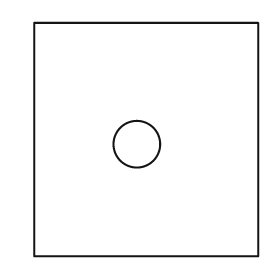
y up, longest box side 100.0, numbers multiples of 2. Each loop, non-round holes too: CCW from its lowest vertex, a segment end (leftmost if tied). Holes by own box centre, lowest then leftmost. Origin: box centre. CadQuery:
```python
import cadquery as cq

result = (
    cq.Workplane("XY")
    .moveTo(-48.0, -50.0)
    .lineTo(48.0, -50.0)
    .lineTo(48.0, 50.0)
    .lineTo(-48.0, 50.0)
    .close()
    .moveTo(-4.0, -2.0)
    .circle(10.0)
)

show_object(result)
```